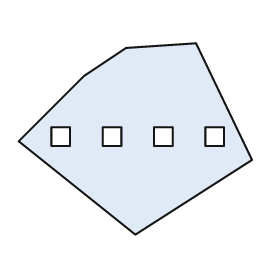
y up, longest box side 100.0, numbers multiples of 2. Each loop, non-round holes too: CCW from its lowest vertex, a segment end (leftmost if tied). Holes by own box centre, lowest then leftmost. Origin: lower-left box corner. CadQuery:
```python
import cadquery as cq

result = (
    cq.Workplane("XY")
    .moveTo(50.0, 0.0)
    .lineTo(100.0, 32.0)
    .lineTo(76.0, 82.0)
    .lineTo(46.0, 80.0)
    .lineTo(28.0, 68.0)
    .lineTo(0.0, 40.0)
    .close()
    .moveTo(14.0, 38.0)
    .lineTo(22.0, 38.0)
    .lineTo(22.0, 46.0)
    .lineTo(14.0, 46.0)
    .close()
    .moveTo(36.0, 38.0)
    .lineTo(44.0, 38.0)
    .lineTo(44.0, 46.0)
    .lineTo(36.0, 46.0)
    .close()
    .moveTo(58.0, 38.0)
    .lineTo(66.0, 38.0)
    .lineTo(66.0, 46.0)
    .lineTo(58.0, 46.0)
    .close()
    .moveTo(80.0, 38.0)
    .lineTo(88.0, 38.0)
    .lineTo(88.0, 46.0)
    .lineTo(80.0, 46.0)
    .close()
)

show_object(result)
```